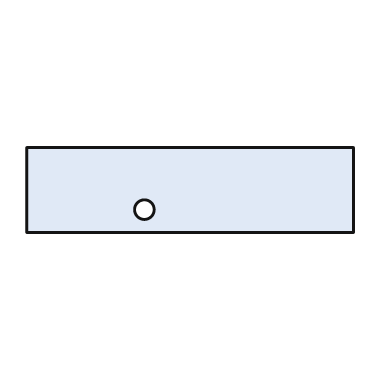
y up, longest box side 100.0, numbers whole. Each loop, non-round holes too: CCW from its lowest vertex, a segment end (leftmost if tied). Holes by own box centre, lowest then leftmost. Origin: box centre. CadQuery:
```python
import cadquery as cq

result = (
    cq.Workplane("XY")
    .moveTo(-50.0, -13.0)
    .lineTo(50.0, -13.0)
    .lineTo(50.0, 13.0)
    .lineTo(-50.0, 13.0)
    .close()
    .moveTo(-14.0, -6.0)
    .circle(3.0)
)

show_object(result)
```